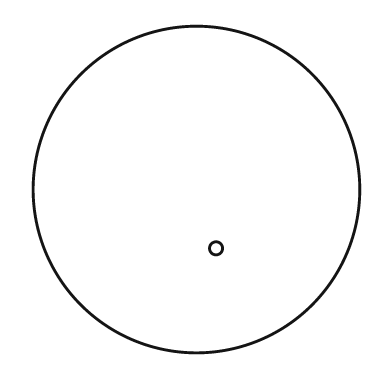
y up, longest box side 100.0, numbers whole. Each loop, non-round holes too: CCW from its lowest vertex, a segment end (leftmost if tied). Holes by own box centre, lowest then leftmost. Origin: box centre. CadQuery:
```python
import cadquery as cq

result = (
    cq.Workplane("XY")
    .moveTo(0.0, 0.0)
    .circle(50.0)
    .moveTo(6.0, -18.0)
    .circle(2.0)
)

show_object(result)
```